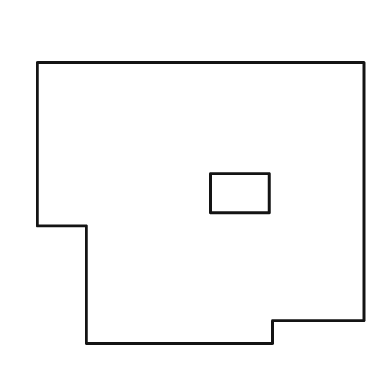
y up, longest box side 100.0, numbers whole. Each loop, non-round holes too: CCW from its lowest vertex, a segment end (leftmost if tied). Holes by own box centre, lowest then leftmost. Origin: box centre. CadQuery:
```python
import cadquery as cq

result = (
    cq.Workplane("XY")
    .moveTo(-35.0, -43.0)
    .lineTo(22.0, -43.0)
    .lineTo(22.0, -36.0)
    .lineTo(50.0, -36.0)
    .lineTo(50.0, 43.0)
    .lineTo(-50.0, 43.0)
    .lineTo(-50.0, -7.0)
    .lineTo(-35.0, -7.0)
    .close()
    .moveTo(3.0, -3.0)
    .lineTo(21.0, -3.0)
    .lineTo(21.0, 9.0)
    .lineTo(3.0, 9.0)
    .close()
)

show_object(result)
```